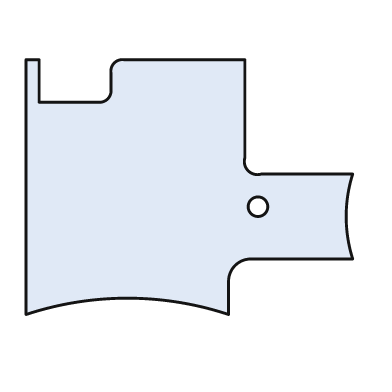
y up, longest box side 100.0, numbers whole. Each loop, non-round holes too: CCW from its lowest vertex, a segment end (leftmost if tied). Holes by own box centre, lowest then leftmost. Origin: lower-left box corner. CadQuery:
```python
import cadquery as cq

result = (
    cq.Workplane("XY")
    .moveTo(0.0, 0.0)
    .threePointArc((31.0, 5.0), (62.0, 0.0))
    .lineTo(62.0, 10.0)
    .threePointArc((64.0, 15.0), (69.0, 17.0))
    .lineTo(100.0, 17.0)
    .threePointArc((98.0, 30.0), (100.0, 43.0))
    .lineTo(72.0, 43.0)
    .threePointArc((68.0, 44.0), (67.0, 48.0))
    .lineTo(67.0, 78.0)
    .lineTo(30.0, 78.0)
    .threePointArc((27.0, 77.0), (26.0, 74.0))
    .lineTo(26.0, 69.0)
    .threePointArc((25.0, 66.0), (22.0, 65.0))
    .lineTo(4.0, 65.0)
    .lineTo(4.0, 78.0)
    .lineTo(0.0, 78.0)
    .close()
    .moveTo(71.0, 33.0)
    .circle(3.0)
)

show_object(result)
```